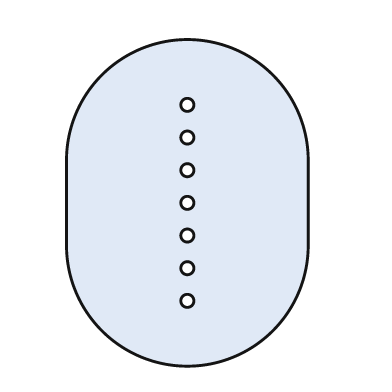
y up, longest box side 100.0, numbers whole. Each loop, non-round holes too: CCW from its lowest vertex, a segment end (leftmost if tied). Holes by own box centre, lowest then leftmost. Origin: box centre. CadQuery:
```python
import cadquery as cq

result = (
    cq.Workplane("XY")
    .moveTo(-37.0, -13.0)
    .threePointArc((0.0, -50.0), (37.0, -13.0))
    .lineTo(37.0, 13.0)
    .threePointArc((0.0, 50.0), (-37.0, 13.0))
    .close()
    .moveTo(0.0, -30.0)
    .circle(2.0)
    .moveTo(0.0, -20.0)
    .circle(2.0)
    .moveTo(0.0, -10.0)
    .circle(2.0)
    .moveTo(0.0, 0.0)
    .circle(2.0)
    .moveTo(0.0, 10.0)
    .circle(2.0)
    .moveTo(0.0, 20.0)
    .circle(2.0)
    .moveTo(0.0, 30.0)
    .circle(2.0)
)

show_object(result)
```